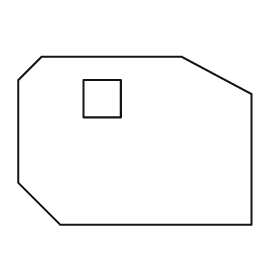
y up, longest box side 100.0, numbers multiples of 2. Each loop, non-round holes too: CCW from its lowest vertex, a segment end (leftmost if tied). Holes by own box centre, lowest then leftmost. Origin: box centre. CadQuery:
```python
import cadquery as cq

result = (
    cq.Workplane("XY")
    .moveTo(-32.0, -36.0)
    .lineTo(50.0, -36.0)
    .lineTo(50.0, 20.0)
    .lineTo(20.0, 36.0)
    .lineTo(-40.0, 36.0)
    .lineTo(-50.0, 26.0)
    .lineTo(-50.0, -18.0)
    .close()
    .moveTo(-22.0, 10.0)
    .lineTo(-6.0, 10.0)
    .lineTo(-6.0, 26.0)
    .lineTo(-22.0, 26.0)
    .close()
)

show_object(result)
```